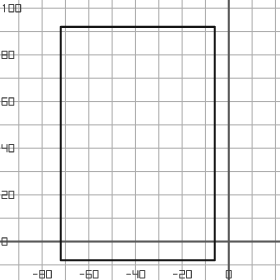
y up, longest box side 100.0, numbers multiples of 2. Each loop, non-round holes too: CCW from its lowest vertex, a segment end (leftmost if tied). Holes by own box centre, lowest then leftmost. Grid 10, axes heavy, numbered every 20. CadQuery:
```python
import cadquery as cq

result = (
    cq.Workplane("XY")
    .moveTo(-72.0, -8.0)
    .lineTo(-6.0, -8.0)
    .lineTo(-6.0, 92.0)
    .lineTo(-72.0, 92.0)
    .close()
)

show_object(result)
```